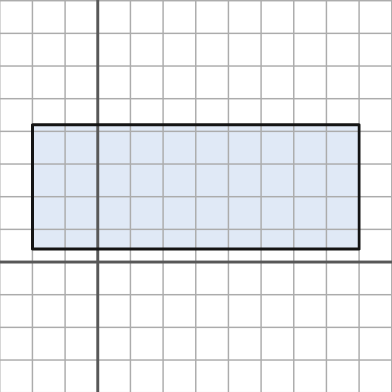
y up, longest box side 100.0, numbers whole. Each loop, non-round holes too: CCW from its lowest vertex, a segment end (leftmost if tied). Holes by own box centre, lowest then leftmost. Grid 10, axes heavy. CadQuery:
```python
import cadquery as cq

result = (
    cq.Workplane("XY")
    .moveTo(-20.0, 4.0)
    .lineTo(80.0, 4.0)
    .lineTo(80.0, 42.0)
    .lineTo(-20.0, 42.0)
    .close()
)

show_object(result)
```